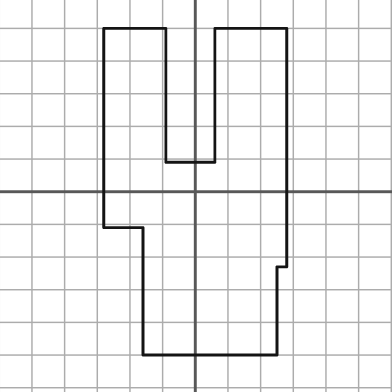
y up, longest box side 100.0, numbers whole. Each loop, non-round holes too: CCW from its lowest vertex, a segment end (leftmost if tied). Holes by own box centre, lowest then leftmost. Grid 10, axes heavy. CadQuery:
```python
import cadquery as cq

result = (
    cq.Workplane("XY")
    .moveTo(-16.0, -50.0)
    .lineTo(25.0, -50.0)
    .lineTo(25.0, -23.0)
    .lineTo(28.0, -23.0)
    .lineTo(28.0, 50.0)
    .lineTo(6.0, 50.0)
    .lineTo(6.0, 9.0)
    .lineTo(-9.0, 9.0)
    .lineTo(-9.0, 50.0)
    .lineTo(-28.0, 50.0)
    .lineTo(-28.0, -11.0)
    .lineTo(-16.0, -11.0)
    .close()
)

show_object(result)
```